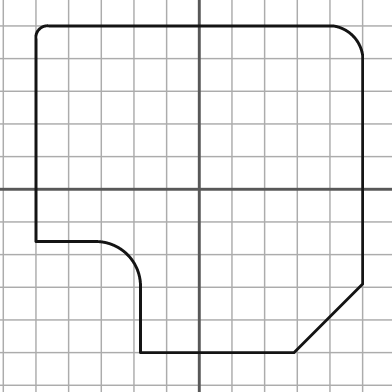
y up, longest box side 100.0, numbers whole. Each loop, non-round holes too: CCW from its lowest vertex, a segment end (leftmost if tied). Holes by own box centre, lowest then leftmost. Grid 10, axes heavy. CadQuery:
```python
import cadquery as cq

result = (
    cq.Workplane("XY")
    .moveTo(-18.0, -50.0)
    .lineTo(29.0, -50.0)
    .lineTo(50.0, -29.0)
    .lineTo(50.0, 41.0)
    .threePointArc((47.0, 47.0), (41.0, 50.0))
    .lineTo(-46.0, 50.0)
    .threePointArc((-49.0, 49.0), (-50.0, 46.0))
    .lineTo(-50.0, -16.0)
    .lineTo(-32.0, -16.0)
    .threePointArc((-22.0, -20.0), (-18.0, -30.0))
    .close()
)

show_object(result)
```